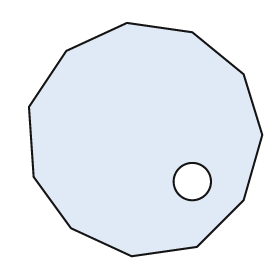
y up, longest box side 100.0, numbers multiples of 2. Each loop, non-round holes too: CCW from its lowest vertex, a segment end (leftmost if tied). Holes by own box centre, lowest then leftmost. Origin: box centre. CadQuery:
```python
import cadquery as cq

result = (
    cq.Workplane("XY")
    .moveTo(-6.0, -50.0)
    .lineTo(22.0, -46.0)
    .lineTo(42.0, -26.0)
    .lineTo(50.0, 2.0)
    .lineTo(42.0, 28.0)
    .lineTo(20.0, 46.0)
    .lineTo(-8.0, 50.0)
    .lineTo(-34.0, 38.0)
    .lineTo(-50.0, 14.0)
    .lineTo(-48.0, -16.0)
    .lineTo(-32.0, -38.0)
    .close()
    .moveTo(20.0, -18.0)
    .circle(8.0)
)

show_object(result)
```